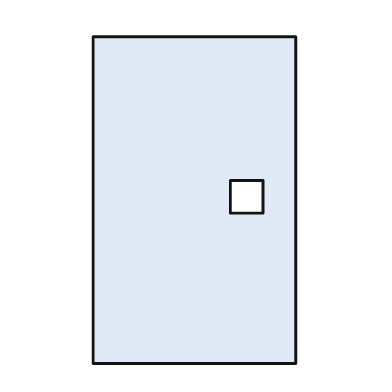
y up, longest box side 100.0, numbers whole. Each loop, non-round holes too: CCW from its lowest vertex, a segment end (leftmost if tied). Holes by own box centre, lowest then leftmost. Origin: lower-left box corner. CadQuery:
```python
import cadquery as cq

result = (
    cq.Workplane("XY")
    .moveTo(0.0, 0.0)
    .lineTo(62.0, 0.0)
    .lineTo(62.0, 100.0)
    .lineTo(0.0, 100.0)
    .close()
    .moveTo(42.0, 46.0)
    .lineTo(52.0, 46.0)
    .lineTo(52.0, 56.0)
    .lineTo(42.0, 56.0)
    .close()
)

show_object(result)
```